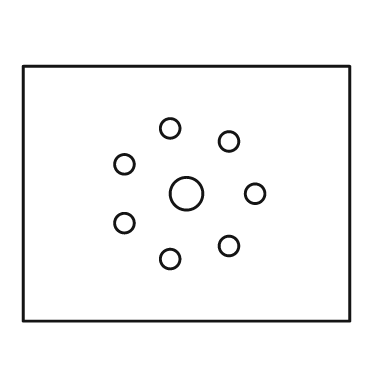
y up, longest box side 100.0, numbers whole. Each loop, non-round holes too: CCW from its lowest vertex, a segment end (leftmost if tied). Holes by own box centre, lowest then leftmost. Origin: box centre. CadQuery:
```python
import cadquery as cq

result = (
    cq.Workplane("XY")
    .moveTo(-50.0, -39.0)
    .lineTo(50.0, -39.0)
    .lineTo(50.0, 39.0)
    .lineTo(-50.0, 39.0)
    .close()
    .moveTo(-5.0, -20.0)
    .circle(3.0)
    .moveTo(13.0, -16.0)
    .circle(3.0)
    .moveTo(-19.0, -9.0)
    .circle(3.0)
    .moveTo(0.0, 0.0)
    .circle(5.0)
    .moveTo(21.0, 0.0)
    .circle(3.0)
    .moveTo(-19.0, 9.0)
    .circle(3.0)
    .moveTo(13.0, 16.0)
    .circle(3.0)
    .moveTo(-5.0, 20.0)
    .circle(3.0)
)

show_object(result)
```